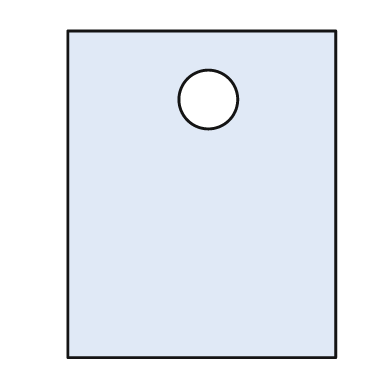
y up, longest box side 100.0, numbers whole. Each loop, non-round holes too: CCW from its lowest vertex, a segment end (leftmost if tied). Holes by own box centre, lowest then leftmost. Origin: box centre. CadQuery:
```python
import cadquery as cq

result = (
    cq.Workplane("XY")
    .moveTo(-41.0, -50.0)
    .lineTo(41.0, -50.0)
    .lineTo(41.0, 50.0)
    .lineTo(-41.0, 50.0)
    .close()
    .moveTo(2.0, 29.0)
    .circle(9.0)
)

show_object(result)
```